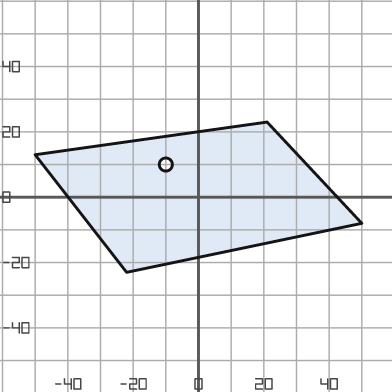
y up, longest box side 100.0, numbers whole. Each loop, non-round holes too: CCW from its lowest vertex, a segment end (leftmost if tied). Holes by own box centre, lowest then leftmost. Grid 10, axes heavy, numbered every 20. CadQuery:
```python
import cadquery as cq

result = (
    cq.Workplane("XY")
    .moveTo(-22.0, -23.0)
    .lineTo(50.0, -8.0)
    .lineTo(21.0, 23.0)
    .lineTo(-50.0, 13.0)
    .close()
    .moveTo(-10.0, 10.0)
    .circle(2.0)
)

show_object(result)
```